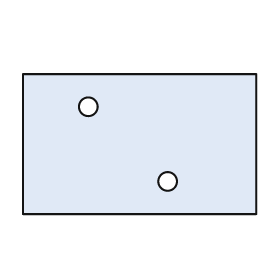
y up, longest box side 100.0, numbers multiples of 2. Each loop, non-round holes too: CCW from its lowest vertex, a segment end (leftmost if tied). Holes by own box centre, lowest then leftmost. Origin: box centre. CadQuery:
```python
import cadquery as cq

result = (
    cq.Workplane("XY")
    .moveTo(-50.0, -30.0)
    .lineTo(50.0, -30.0)
    .lineTo(50.0, 30.0)
    .lineTo(-50.0, 30.0)
    .close()
    .moveTo(12.0, -16.0)
    .circle(4.0)
    .moveTo(-22.0, 16.0)
    .circle(4.0)
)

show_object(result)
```